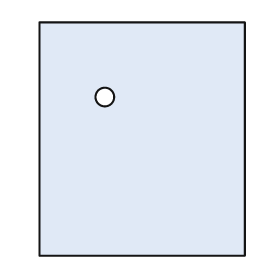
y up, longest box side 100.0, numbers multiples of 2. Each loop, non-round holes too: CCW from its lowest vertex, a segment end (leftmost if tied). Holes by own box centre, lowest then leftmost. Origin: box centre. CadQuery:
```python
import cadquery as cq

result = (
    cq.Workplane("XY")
    .moveTo(-44.0, -50.0)
    .lineTo(44.0, -50.0)
    .lineTo(44.0, 50.0)
    .lineTo(-44.0, 50.0)
    .close()
    .moveTo(-16.0, 18.0)
    .circle(4.0)
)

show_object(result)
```